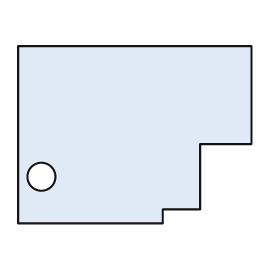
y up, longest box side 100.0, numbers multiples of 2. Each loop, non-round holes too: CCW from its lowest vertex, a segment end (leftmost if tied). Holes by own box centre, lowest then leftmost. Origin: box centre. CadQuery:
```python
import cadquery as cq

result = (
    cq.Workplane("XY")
    .moveTo(-50.0, -38.0)
    .lineTo(12.0, -38.0)
    .lineTo(12.0, -32.0)
    .lineTo(28.0, -32.0)
    .lineTo(28.0, -4.0)
    .lineTo(50.0, -4.0)
    .lineTo(50.0, 38.0)
    .lineTo(-50.0, 38.0)
    .close()
    .moveTo(-40.0, -18.0)
    .circle(6.0)
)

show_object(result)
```